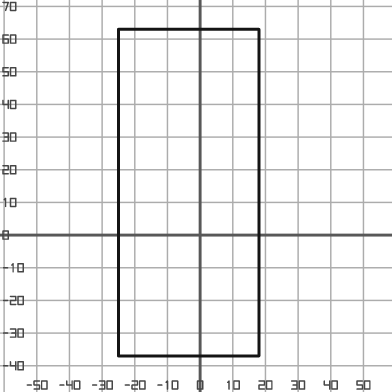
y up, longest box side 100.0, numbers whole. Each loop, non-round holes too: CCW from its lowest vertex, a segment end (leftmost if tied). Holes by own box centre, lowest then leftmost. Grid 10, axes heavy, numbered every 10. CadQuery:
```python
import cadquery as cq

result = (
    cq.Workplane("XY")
    .moveTo(-25.0, -37.0)
    .lineTo(18.0, -37.0)
    .lineTo(18.0, 63.0)
    .lineTo(-25.0, 63.0)
    .close()
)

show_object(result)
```